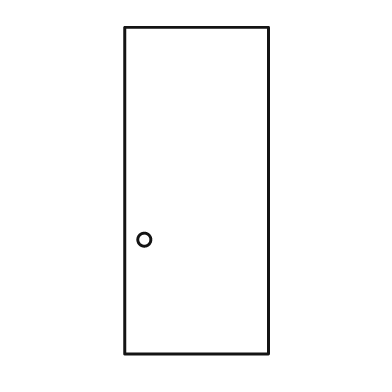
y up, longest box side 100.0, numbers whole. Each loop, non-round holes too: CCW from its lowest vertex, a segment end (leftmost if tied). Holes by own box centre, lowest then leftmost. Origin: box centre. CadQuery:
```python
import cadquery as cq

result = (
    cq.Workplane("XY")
    .moveTo(-22.0, -50.0)
    .lineTo(22.0, -50.0)
    .lineTo(22.0, 50.0)
    .lineTo(-22.0, 50.0)
    .close()
    .moveTo(-16.0, -15.0)
    .circle(2.0)
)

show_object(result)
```